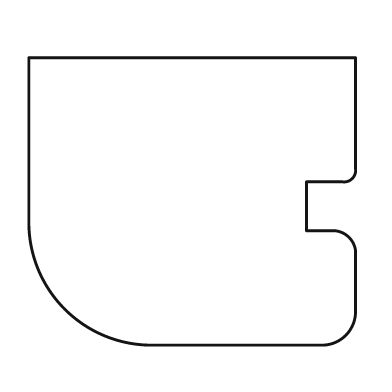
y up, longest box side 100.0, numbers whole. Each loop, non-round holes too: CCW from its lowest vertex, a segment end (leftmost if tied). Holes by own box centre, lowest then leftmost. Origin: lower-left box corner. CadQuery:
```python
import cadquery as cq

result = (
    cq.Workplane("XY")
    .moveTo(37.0, 0.0)
    .lineTo(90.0, 0.0)
    .threePointArc((97.0, 3.0), (100.0, 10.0))
    .lineTo(100.0, 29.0)
    .threePointArc((98.0, 33.0), (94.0, 35.0))
    .lineTo(85.0, 35.0)
    .lineTo(85.0, 50.0)
    .lineTo(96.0, 50.0)
    .threePointArc((99.0, 51.0), (100.0, 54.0))
    .lineTo(100.0, 88.0)
    .lineTo(0.0, 88.0)
    .lineTo(0.0, 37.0)
    .threePointArc((11.0, 11.0), (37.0, 0.0))
    .close()
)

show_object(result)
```